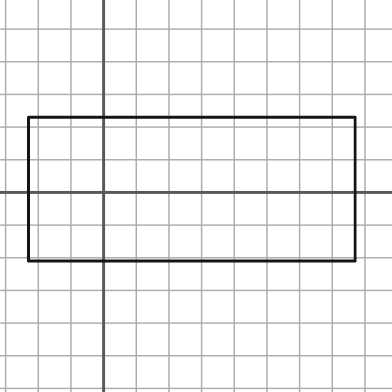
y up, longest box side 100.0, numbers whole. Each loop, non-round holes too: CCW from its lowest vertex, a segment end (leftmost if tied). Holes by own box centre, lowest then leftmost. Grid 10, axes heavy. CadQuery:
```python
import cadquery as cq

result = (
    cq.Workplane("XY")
    .moveTo(-23.0, -21.0)
    .lineTo(77.0, -21.0)
    .lineTo(77.0, 23.0)
    .lineTo(-23.0, 23.0)
    .close()
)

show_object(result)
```